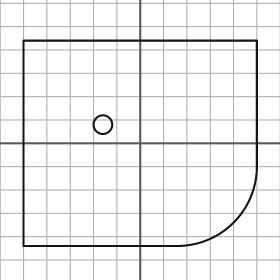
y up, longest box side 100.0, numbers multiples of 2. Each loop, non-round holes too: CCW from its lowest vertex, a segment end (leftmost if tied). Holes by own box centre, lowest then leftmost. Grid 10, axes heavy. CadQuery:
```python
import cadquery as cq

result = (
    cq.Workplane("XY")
    .moveTo(-50.0, -44.0)
    .lineTo(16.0, -44.0)
    .threePointArc((40.0, -34.0), (50.0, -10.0))
    .lineTo(50.0, 44.0)
    .lineTo(-50.0, 44.0)
    .close()
    .moveTo(-16.0, 8.0)
    .circle(4.0)
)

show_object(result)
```